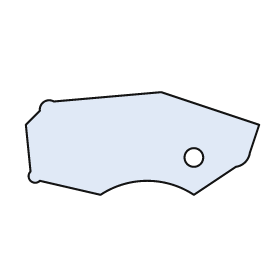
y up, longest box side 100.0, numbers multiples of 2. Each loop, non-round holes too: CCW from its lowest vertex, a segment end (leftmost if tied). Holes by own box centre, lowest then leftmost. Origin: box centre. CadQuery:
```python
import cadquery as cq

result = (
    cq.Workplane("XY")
    .moveTo(-18.0, -22.0)
    .threePointArc((2.0, -16.0), (22.0, -22.0))
    .lineTo(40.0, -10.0)
    .threePointArc((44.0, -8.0), (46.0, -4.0))
    .lineTo(50.0, 8.0)
    .lineTo(8.0, 22.0)
    .lineTo(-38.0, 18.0)
    .threePointArc((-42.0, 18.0), (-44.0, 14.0))
    .lineTo(-50.0, 8.0)
    .lineTo(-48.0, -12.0)
    .threePointArc((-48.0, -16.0), (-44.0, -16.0))
    .close()
    .moveTo(22.0, -6.0)
    .circle(4.0)
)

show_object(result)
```